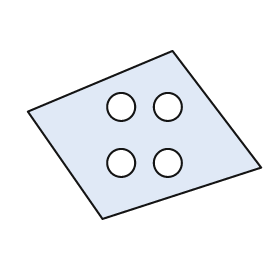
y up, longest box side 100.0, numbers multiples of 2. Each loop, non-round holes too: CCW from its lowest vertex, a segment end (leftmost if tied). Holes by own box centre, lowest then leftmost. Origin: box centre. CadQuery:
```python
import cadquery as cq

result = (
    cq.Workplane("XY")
    .moveTo(-18.0, -36.0)
    .lineTo(50.0, -14.0)
    .lineTo(12.0, 36.0)
    .lineTo(-50.0, 10.0)
    .close()
    .moveTo(-10.0, -12.0)
    .circle(6.0)
    .moveTo(10.0, -12.0)
    .circle(6.0)
    .moveTo(-10.0, 12.0)
    .circle(6.0)
    .moveTo(10.0, 12.0)
    .circle(6.0)
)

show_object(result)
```